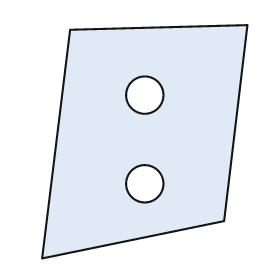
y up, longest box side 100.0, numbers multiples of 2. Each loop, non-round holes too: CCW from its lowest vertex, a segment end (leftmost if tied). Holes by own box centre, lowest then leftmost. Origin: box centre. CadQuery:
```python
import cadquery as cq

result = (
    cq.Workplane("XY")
    .moveTo(-44.0, -50.0)
    .lineTo(34.0, -34.0)
    .lineTo(44.0, 50.0)
    .lineTo(-32.0, 48.0)
    .close()
    .moveTo(0.0, -18.0)
    .circle(8.0)
    .moveTo(0.0, 20.0)
    .circle(8.0)
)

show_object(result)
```